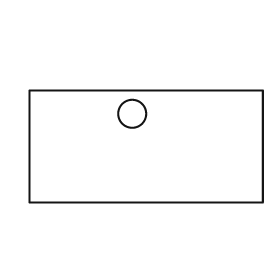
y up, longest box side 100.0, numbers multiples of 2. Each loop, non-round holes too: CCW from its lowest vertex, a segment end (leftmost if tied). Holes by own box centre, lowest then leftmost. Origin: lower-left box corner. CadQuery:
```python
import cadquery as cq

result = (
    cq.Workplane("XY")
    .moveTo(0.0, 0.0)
    .lineTo(100.0, 0.0)
    .lineTo(100.0, 48.0)
    .lineTo(0.0, 48.0)
    .close()
    .moveTo(44.0, 38.0)
    .circle(6.0)
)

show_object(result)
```